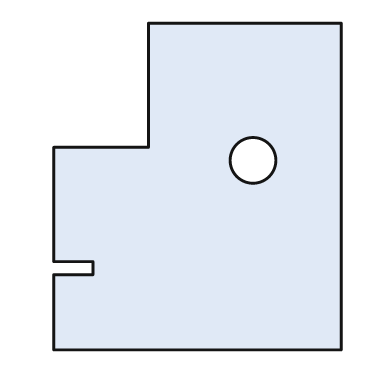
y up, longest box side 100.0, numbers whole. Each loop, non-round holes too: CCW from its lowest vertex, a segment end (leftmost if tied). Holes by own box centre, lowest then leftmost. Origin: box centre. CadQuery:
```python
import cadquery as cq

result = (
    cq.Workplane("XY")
    .moveTo(-44.0, -50.0)
    .lineTo(44.0, -50.0)
    .lineTo(44.0, 50.0)
    .lineTo(-15.0, 50.0)
    .lineTo(-15.0, 12.0)
    .lineTo(-44.0, 12.0)
    .lineTo(-44.0, -23.0)
    .lineTo(-32.0, -23.0)
    .lineTo(-32.0, -27.0)
    .lineTo(-44.0, -27.0)
    .close()
    .moveTo(17.0, 8.0)
    .circle(7.0)
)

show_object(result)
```